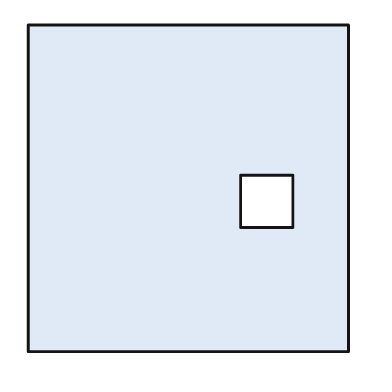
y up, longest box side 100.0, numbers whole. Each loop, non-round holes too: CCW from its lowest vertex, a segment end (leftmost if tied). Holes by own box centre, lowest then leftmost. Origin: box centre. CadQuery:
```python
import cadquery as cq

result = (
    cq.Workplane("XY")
    .moveTo(-49.0, -50.0)
    .lineTo(49.0, -50.0)
    .lineTo(49.0, 50.0)
    .lineTo(-49.0, 50.0)
    .close()
    .moveTo(16.0, -12.0)
    .lineTo(32.0, -12.0)
    .lineTo(32.0, 4.0)
    .lineTo(16.0, 4.0)
    .close()
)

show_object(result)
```